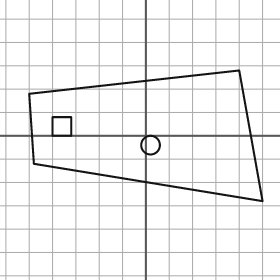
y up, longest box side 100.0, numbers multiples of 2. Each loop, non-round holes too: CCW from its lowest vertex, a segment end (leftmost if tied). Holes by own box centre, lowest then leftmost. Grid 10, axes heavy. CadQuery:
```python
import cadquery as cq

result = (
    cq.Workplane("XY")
    .moveTo(50.0, -28.0)
    .lineTo(40.0, 28.0)
    .lineTo(-50.0, 18.0)
    .lineTo(-48.0, -12.0)
    .close()
    .moveTo(2.0, -4.0)
    .circle(4.0)
    .moveTo(-40.0, 0.0)
    .lineTo(-32.0, 0.0)
    .lineTo(-32.0, 8.0)
    .lineTo(-40.0, 8.0)
    .close()
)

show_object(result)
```